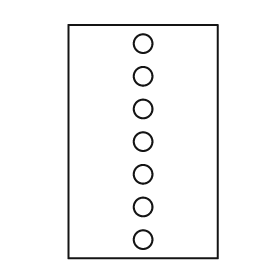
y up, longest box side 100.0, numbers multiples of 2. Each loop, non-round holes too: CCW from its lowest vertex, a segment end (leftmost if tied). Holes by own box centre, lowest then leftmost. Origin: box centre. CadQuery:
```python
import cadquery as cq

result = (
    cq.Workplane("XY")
    .moveTo(-32.0, -50.0)
    .lineTo(32.0, -50.0)
    .lineTo(32.0, 50.0)
    .lineTo(-32.0, 50.0)
    .close()
    .moveTo(0.0, -42.0)
    .circle(4.0)
    .moveTo(0.0, -28.0)
    .circle(4.0)
    .moveTo(0.0, -14.0)
    .circle(4.0)
    .moveTo(0.0, 0.0)
    .circle(4.0)
    .moveTo(0.0, 14.0)
    .circle(4.0)
    .moveTo(0.0, 28.0)
    .circle(4.0)
    .moveTo(0.0, 42.0)
    .circle(4.0)
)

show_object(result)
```